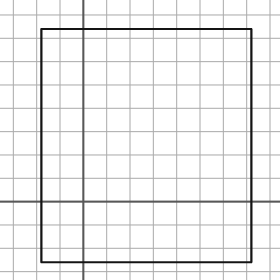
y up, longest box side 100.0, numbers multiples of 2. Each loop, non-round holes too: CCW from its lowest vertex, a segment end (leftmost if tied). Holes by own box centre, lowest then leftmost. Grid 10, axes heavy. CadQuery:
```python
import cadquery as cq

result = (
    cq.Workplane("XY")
    .moveTo(-18.0, -26.0)
    .lineTo(72.0, -26.0)
    .lineTo(72.0, 74.0)
    .lineTo(-18.0, 74.0)
    .close()
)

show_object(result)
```